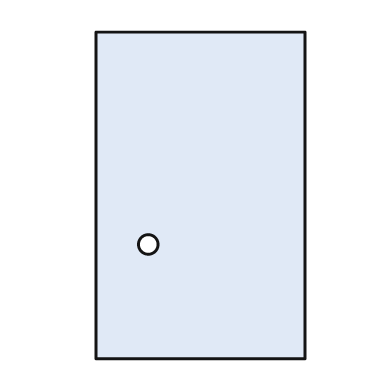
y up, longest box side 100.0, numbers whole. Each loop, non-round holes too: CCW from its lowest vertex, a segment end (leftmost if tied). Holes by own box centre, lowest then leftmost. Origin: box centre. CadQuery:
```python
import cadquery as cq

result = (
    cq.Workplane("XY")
    .moveTo(-32.0, -50.0)
    .lineTo(32.0, -50.0)
    .lineTo(32.0, 50.0)
    .lineTo(-32.0, 50.0)
    .close()
    .moveTo(-16.0, -15.0)
    .circle(3.0)
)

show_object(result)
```